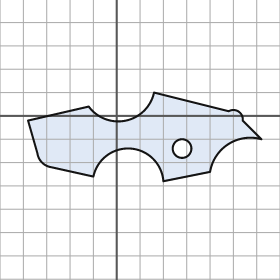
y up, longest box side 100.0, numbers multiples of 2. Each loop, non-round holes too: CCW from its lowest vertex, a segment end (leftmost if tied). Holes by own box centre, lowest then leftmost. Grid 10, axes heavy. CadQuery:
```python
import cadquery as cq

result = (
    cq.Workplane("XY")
    .moveTo(20.0, -28.0)
    .lineTo(40.0, -24.0)
    .threePointArc((48.0, -12.0), (62.0, -10.0))
    .lineTo(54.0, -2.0)
    .threePointArc((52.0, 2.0), (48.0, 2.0))
    .lineTo(16.0, 10.0)
    .threePointArc((4.0, -2.0), (-12.0, 4.0))
    .lineTo(-38.0, -2.0)
    .lineTo(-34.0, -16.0)
    .threePointArc((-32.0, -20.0), (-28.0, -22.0))
    .lineTo(-10.0, -26.0)
    .threePointArc((6.0, -14.0), (20.0, -28.0))
    .close()
    .moveTo(28.0, -14.0)
    .circle(4.0)
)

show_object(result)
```